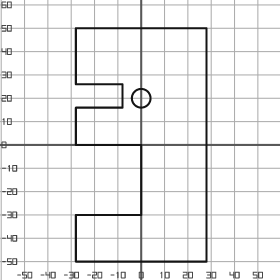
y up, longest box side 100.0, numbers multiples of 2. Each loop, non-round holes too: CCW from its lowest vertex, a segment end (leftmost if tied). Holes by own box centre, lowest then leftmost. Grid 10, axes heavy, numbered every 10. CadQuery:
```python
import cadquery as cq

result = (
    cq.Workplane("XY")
    .moveTo(-28.0, -50.0)
    .lineTo(28.0, -50.0)
    .lineTo(28.0, 50.0)
    .lineTo(-28.0, 50.0)
    .lineTo(-28.0, 26.0)
    .lineTo(-8.0, 26.0)
    .lineTo(-8.0, 16.0)
    .lineTo(-28.0, 16.0)
    .lineTo(-28.0, 0.0)
    .lineTo(0.0, 0.0)
    .lineTo(0.0, -30.0)
    .lineTo(-28.0, -30.0)
    .close()
    .moveTo(0.0, 20.0)
    .circle(4.0)
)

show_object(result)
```